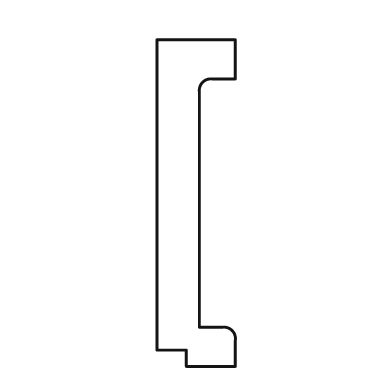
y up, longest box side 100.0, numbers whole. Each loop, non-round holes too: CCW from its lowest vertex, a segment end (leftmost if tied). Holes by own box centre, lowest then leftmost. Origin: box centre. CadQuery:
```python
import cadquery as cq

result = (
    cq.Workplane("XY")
    .moveTo(-3.0, -50.0)
    .lineTo(12.0, -50.0)
    .lineTo(12.0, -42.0)
    .threePointArc((11.0, -39.0), (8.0, -38.0))
    .lineTo(1.0, -38.0)
    .lineTo(1.0, 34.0)
    .threePointArc((2.0, 37.0), (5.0, 38.0))
    .lineTo(12.0, 38.0)
    .lineTo(12.0, 50.0)
    .lineTo(-12.0, 50.0)
    .lineTo(-12.0, -45.0)
    .lineTo(-3.0, -45.0)
    .close()
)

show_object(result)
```